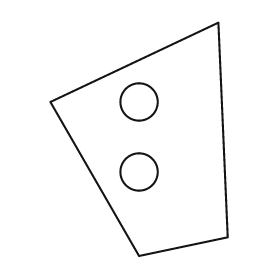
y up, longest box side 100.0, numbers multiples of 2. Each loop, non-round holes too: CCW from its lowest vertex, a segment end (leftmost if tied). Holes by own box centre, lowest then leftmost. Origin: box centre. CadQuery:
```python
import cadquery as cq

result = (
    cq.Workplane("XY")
    .moveTo(0.0, -50.0)
    .lineTo(38.0, -42.0)
    .lineTo(34.0, 50.0)
    .lineTo(-38.0, 16.0)
    .close()
    .moveTo(0.0, -14.0)
    .circle(8.0)
    .moveTo(0.0, 16.0)
    .circle(8.0)
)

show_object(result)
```